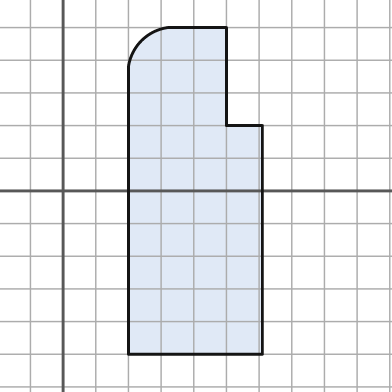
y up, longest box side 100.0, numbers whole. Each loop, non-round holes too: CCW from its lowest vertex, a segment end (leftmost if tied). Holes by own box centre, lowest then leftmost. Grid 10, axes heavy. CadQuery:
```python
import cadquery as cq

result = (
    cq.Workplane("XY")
    .moveTo(20.0, -50.0)
    .lineTo(61.0, -50.0)
    .lineTo(61.0, 20.0)
    .lineTo(50.0, 20.0)
    .lineTo(50.0, 50.0)
    .lineTo(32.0, 50.0)
    .threePointArc((24.0, 46.0), (20.0, 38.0))
    .close()
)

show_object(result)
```